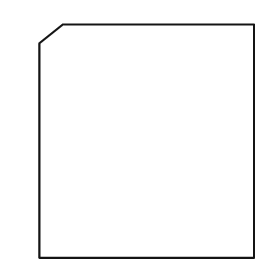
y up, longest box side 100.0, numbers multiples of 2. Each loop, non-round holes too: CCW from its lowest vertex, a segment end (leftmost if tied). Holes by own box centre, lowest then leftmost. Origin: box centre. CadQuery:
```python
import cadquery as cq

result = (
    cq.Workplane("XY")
    .moveTo(-46.0, -50.0)
    .lineTo(46.0, -50.0)
    .lineTo(46.0, 50.0)
    .lineTo(-36.0, 50.0)
    .lineTo(-46.0, 42.0)
    .close()
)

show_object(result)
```